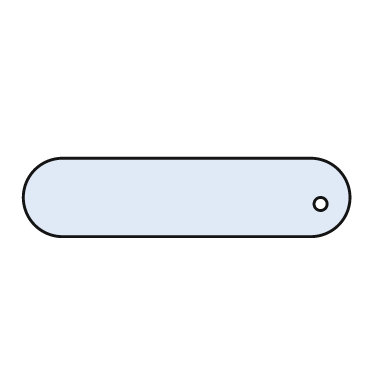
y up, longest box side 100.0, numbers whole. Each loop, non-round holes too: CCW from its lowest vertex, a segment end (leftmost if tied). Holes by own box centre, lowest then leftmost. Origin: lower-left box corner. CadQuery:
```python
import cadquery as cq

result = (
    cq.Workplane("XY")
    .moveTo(12.0, 0.0)
    .lineTo(88.0, 0.0)
    .threePointArc((100.0, 12.0), (88.0, 24.0))
    .lineTo(12.0, 24.0)
    .threePointArc((0.0, 12.0), (12.0, 0.0))
    .close()
    .moveTo(91.0, 10.0)
    .circle(2.0)
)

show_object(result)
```